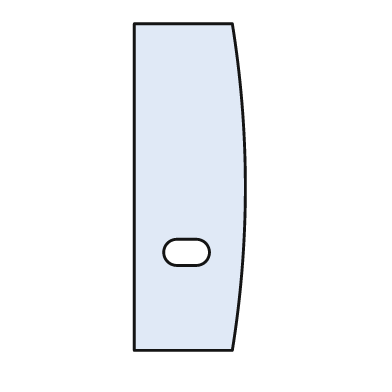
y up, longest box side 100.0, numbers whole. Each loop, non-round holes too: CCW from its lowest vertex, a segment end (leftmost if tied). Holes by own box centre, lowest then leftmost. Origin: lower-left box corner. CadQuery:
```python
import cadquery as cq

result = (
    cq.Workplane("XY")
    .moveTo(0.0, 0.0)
    .lineTo(30.0, 0.0)
    .threePointArc((34.0, 50.0), (30.0, 100.0))
    .lineTo(0.0, 100.0)
    .close()
    .moveTo(13.0, 26.0)
    .lineTo(19.0, 26.0)
    .threePointArc((23.0, 30.0), (19.0, 34.0))
    .lineTo(13.0, 34.0)
    .threePointArc((9.0, 30.0), (13.0, 26.0))
    .close()
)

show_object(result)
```